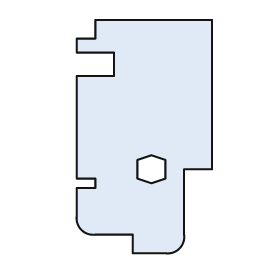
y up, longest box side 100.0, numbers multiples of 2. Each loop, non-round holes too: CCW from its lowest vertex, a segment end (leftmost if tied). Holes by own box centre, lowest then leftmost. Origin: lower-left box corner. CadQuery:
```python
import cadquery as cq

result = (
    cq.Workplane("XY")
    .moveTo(24.0, 0.0)
    .lineTo(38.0, 0.0)
    .threePointArc((44.0, 2.0), (46.0, 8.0))
    .lineTo(46.0, 36.0)
    .lineTo(58.0, 36.0)
    .lineTo(58.0, 100.0)
    .lineTo(8.0, 100.0)
    .lineTo(8.0, 92.0)
    .lineTo(0.0, 92.0)
    .lineTo(0.0, 86.0)
    .lineTo(16.0, 86.0)
    .lineTo(16.0, 76.0)
    .lineTo(0.0, 76.0)
    .lineTo(0.0, 32.0)
    .lineTo(8.0, 32.0)
    .lineTo(8.0, 28.0)
    .lineTo(0.0, 28.0)
    .lineTo(0.0, 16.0)
    .threePointArc((2.0, 10.0), (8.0, 8.0))
    .lineTo(24.0, 8.0)
    .close()
    .moveTo(32.0, 30.0)
    .lineTo(38.0, 32.0)
    .lineTo(38.0, 40.0)
    .lineTo(32.0, 42.0)
    .lineTo(26.0, 40.0)
    .lineTo(26.0, 32.0)
    .close()
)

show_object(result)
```